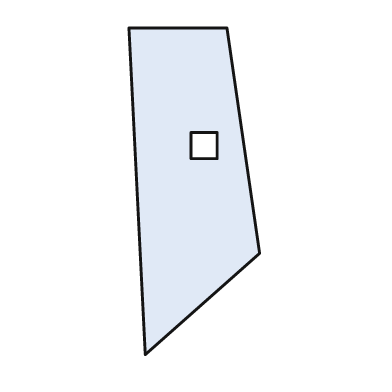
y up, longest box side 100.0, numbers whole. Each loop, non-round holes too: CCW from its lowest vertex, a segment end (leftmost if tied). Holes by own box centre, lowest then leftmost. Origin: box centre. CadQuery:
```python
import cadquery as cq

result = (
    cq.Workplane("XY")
    .moveTo(-15.0, -50.0)
    .lineTo(20.0, -19.0)
    .lineTo(10.0, 50.0)
    .lineTo(-20.0, 50.0)
    .close()
    .moveTo(-1.0, 10.0)
    .lineTo(7.0, 10.0)
    .lineTo(7.0, 18.0)
    .lineTo(-1.0, 18.0)
    .close()
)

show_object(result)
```